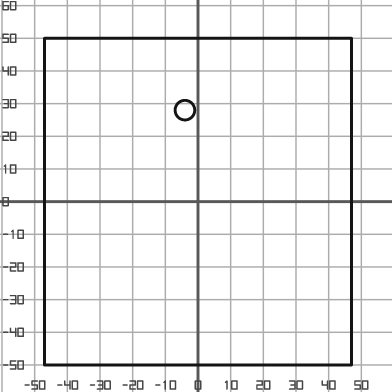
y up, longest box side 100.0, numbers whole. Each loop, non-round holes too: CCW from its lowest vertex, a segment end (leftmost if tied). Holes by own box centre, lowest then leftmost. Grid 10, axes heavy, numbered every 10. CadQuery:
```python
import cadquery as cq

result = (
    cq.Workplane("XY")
    .moveTo(-47.0, -50.0)
    .lineTo(47.0, -50.0)
    .lineTo(47.0, 50.0)
    .lineTo(-47.0, 50.0)
    .close()
    .moveTo(-4.0, 28.0)
    .circle(3.0)
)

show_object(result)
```